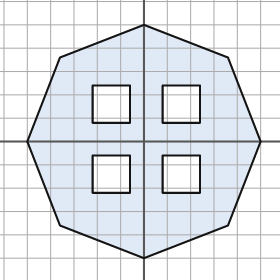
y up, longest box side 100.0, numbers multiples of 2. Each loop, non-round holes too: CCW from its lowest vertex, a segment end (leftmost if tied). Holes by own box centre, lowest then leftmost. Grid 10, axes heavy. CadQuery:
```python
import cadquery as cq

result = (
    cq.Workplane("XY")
    .moveTo(0.0, -50.0)
    .lineTo(36.0, -36.0)
    .lineTo(50.0, 0.0)
    .lineTo(36.0, 36.0)
    .lineTo(0.0, 50.0)
    .lineTo(-36.0, 36.0)
    .lineTo(-50.0, 0.0)
    .lineTo(-36.0, -36.0)
    .close()
    .moveTo(-22.0, -22.0)
    .lineTo(-6.0, -22.0)
    .lineTo(-6.0, -6.0)
    .lineTo(-22.0, -6.0)
    .close()
    .moveTo(8.0, -22.0)
    .lineTo(24.0, -22.0)
    .lineTo(24.0, -6.0)
    .lineTo(8.0, -6.0)
    .close()
    .moveTo(-22.0, 8.0)
    .lineTo(-6.0, 8.0)
    .lineTo(-6.0, 24.0)
    .lineTo(-22.0, 24.0)
    .close()
    .moveTo(8.0, 8.0)
    .lineTo(24.0, 8.0)
    .lineTo(24.0, 24.0)
    .lineTo(8.0, 24.0)
    .close()
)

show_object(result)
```